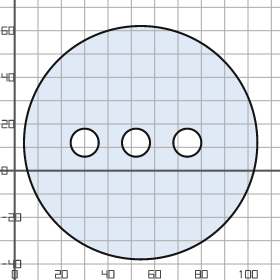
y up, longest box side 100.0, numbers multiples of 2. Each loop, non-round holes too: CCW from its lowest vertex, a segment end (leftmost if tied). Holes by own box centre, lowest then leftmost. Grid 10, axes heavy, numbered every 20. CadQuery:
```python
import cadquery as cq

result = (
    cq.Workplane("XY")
    .moveTo(54.0, 12.0)
    .circle(50.0)
    .moveTo(30.0, 12.0)
    .circle(6.0)
    .moveTo(52.0, 12.0)
    .circle(6.0)
    .moveTo(74.0, 12.0)
    .circle(6.0)
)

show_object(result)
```